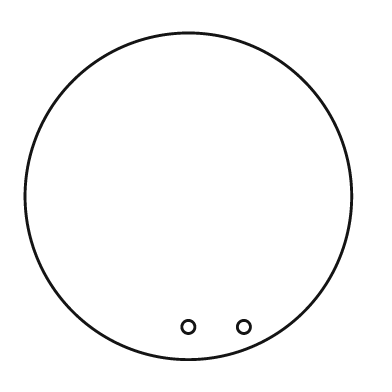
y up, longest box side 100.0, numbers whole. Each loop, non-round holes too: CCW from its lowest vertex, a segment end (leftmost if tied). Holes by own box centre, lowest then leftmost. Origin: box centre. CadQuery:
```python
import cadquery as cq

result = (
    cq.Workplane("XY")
    .moveTo(0.0, 0.0)
    .circle(50.0)
    .moveTo(0.0, -40.0)
    .circle(2.0)
    .moveTo(17.0, -40.0)
    .circle(2.0)
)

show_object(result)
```